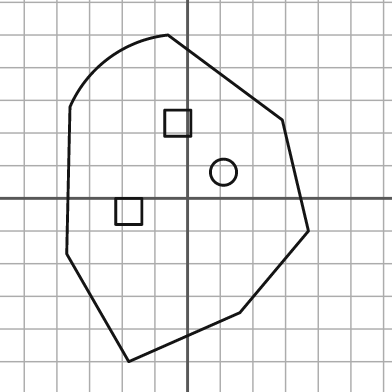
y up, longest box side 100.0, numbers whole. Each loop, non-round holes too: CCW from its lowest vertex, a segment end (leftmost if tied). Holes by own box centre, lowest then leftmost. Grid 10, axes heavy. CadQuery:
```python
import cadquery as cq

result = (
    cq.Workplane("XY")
    .moveTo(-18.0, -50.0)
    .lineTo(16.0, -35.0)
    .lineTo(37.0, -10.0)
    .lineTo(29.0, 24.0)
    .lineTo(-6.0, 50.0)
    .threePointArc((-24.0, 43.0), (-36.0, 28.0))
    .lineTo(-37.0, -17.0)
    .close()
    .moveTo(-22.0, -8.0)
    .lineTo(-14.0, -8.0)
    .lineTo(-14.0, 0.0)
    .lineTo(-22.0, 0.0)
    .close()
    .moveTo(11.0, 8.0)
    .circle(4.0)
    .moveTo(-7.0, 19.0)
    .lineTo(1.0, 19.0)
    .lineTo(1.0, 27.0)
    .lineTo(-7.0, 27.0)
    .close()
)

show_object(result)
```